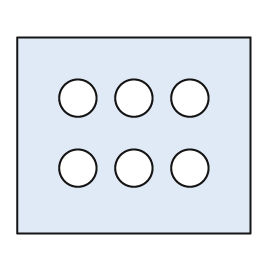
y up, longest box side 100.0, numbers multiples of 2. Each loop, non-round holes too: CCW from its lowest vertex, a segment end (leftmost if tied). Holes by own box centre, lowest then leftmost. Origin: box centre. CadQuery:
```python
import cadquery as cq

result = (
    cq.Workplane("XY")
    .moveTo(-50.0, -42.0)
    .lineTo(50.0, -42.0)
    .lineTo(50.0, 42.0)
    .lineTo(-50.0, 42.0)
    .close()
    .moveTo(-24.0, -14.0)
    .circle(8.0)
    .moveTo(0.0, -14.0)
    .circle(8.0)
    .moveTo(24.0, -14.0)
    .circle(8.0)
    .moveTo(-24.0, 16.0)
    .circle(8.0)
    .moveTo(0.0, 16.0)
    .circle(8.0)
    .moveTo(24.0, 16.0)
    .circle(8.0)
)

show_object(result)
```